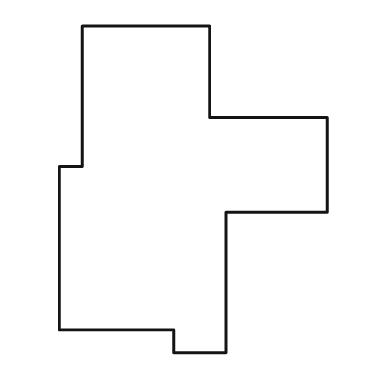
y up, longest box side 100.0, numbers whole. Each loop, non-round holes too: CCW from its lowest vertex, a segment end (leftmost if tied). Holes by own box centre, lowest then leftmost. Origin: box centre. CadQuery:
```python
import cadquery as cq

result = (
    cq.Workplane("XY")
    .moveTo(-6.0, -50.0)
    .lineTo(10.0, -50.0)
    .lineTo(10.0, -7.0)
    .lineTo(41.0, -7.0)
    .lineTo(41.0, 22.0)
    .lineTo(5.0, 22.0)
    .lineTo(5.0, 50.0)
    .lineTo(-34.0, 50.0)
    .lineTo(-34.0, 7.0)
    .lineTo(-41.0, 7.0)
    .lineTo(-41.0, -43.0)
    .lineTo(-6.0, -43.0)
    .close()
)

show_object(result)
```